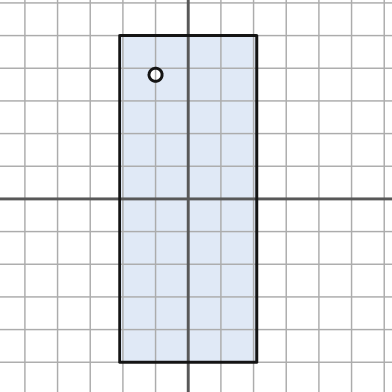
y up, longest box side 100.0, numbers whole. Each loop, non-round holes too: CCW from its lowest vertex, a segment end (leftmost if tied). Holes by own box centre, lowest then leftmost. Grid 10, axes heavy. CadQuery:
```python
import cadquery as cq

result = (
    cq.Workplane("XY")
    .moveTo(-21.0, -50.0)
    .lineTo(21.0, -50.0)
    .lineTo(21.0, 50.0)
    .lineTo(-21.0, 50.0)
    .close()
    .moveTo(-10.0, 38.0)
    .circle(2.0)
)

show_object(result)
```